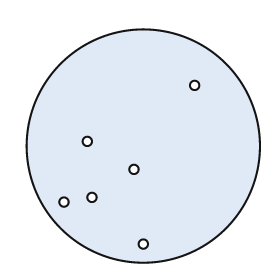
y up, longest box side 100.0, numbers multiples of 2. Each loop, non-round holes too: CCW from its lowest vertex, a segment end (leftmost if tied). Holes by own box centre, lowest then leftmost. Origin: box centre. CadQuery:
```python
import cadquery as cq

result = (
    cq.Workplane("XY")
    .moveTo(0.0, 0.0)
    .circle(50.0)
    .moveTo(0.0, -42.0)
    .circle(2.0)
    .moveTo(-34.0, -24.0)
    .circle(2.0)
    .moveTo(-22.0, -22.0)
    .circle(2.0)
    .moveTo(-4.0, -10.0)
    .circle(2.0)
    .moveTo(-24.0, 2.0)
    .circle(2.0)
    .moveTo(22.0, 26.0)
    .circle(2.0)
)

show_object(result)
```